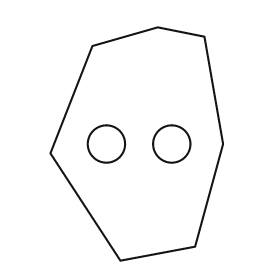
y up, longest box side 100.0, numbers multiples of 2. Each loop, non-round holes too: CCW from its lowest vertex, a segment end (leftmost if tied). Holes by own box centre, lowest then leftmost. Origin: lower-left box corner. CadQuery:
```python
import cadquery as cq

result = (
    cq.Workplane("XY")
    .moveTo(30.0, 0.0)
    .lineTo(62.0, 6.0)
    .lineTo(74.0, 50.0)
    .lineTo(66.0, 96.0)
    .lineTo(46.0, 100.0)
    .lineTo(18.0, 92.0)
    .lineTo(0.0, 46.0)
    .close()
    .moveTo(24.0, 50.0)
    .circle(8.0)
    .moveTo(52.0, 50.0)
    .circle(8.0)
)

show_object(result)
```